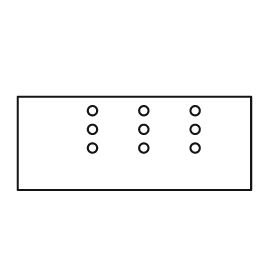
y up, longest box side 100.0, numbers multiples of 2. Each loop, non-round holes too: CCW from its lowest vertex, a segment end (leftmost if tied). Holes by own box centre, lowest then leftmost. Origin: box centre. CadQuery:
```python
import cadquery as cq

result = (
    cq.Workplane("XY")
    .moveTo(-50.0, -20.0)
    .lineTo(50.0, -20.0)
    .lineTo(50.0, 20.0)
    .lineTo(-50.0, 20.0)
    .close()
    .moveTo(-18.0, -2.0)
    .circle(2.0)
    .moveTo(4.0, -2.0)
    .circle(2.0)
    .moveTo(26.0, -2.0)
    .circle(2.0)
    .moveTo(-18.0, 6.0)
    .circle(2.0)
    .moveTo(4.0, 6.0)
    .circle(2.0)
    .moveTo(26.0, 6.0)
    .circle(2.0)
    .moveTo(-18.0, 14.0)
    .circle(2.0)
    .moveTo(4.0, 14.0)
    .circle(2.0)
    .moveTo(26.0, 14.0)
    .circle(2.0)
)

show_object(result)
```